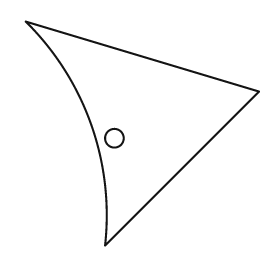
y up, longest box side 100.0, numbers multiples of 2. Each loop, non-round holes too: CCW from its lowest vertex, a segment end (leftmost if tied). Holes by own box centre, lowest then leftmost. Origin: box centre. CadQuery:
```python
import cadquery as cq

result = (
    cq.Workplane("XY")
    .moveTo(-16.0, -48.0)
    .lineTo(50.0, 18.0)
    .lineTo(-50.0, 48.0)
    .threePointArc((-22.0, 4.0), (-16.0, -48.0))
    .close()
    .moveTo(-12.0, -2.0)
    .circle(4.0)
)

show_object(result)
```